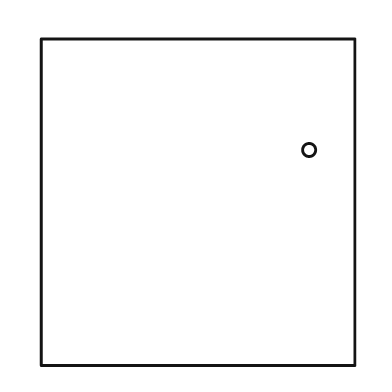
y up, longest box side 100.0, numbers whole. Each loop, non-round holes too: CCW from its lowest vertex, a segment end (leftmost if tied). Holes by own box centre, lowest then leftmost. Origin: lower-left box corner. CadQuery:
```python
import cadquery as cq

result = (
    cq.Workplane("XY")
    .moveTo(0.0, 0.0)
    .lineTo(96.0, 0.0)
    .lineTo(96.0, 100.0)
    .lineTo(0.0, 100.0)
    .close()
    .moveTo(82.0, 66.0)
    .circle(2.0)
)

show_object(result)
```